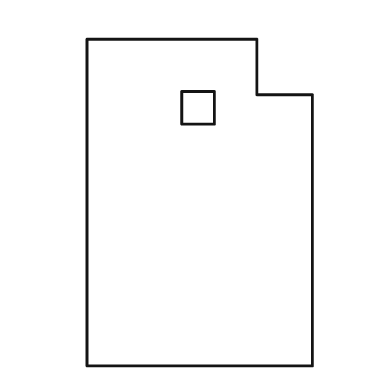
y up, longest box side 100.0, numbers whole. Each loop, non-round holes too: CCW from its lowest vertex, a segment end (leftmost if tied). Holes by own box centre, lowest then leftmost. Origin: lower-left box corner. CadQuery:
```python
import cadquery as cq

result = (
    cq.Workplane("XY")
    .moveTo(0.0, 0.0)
    .lineTo(69.0, 0.0)
    .lineTo(69.0, 83.0)
    .lineTo(52.0, 83.0)
    .lineTo(52.0, 100.0)
    .lineTo(0.0, 100.0)
    .close()
    .moveTo(29.0, 74.0)
    .lineTo(39.0, 74.0)
    .lineTo(39.0, 84.0)
    .lineTo(29.0, 84.0)
    .close()
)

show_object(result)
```